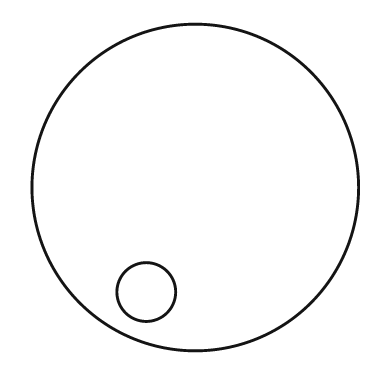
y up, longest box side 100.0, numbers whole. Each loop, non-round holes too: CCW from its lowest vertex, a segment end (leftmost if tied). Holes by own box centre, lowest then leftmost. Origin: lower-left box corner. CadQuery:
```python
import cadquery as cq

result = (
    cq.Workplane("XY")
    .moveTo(50.0, 50.0)
    .circle(50.0)
    .moveTo(35.0, 18.0)
    .circle(9.0)
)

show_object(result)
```